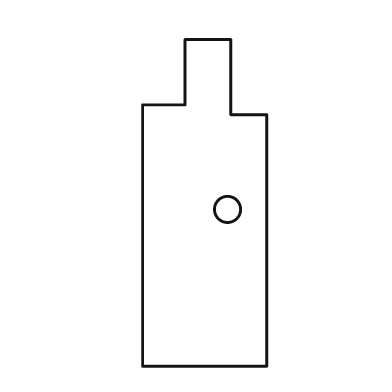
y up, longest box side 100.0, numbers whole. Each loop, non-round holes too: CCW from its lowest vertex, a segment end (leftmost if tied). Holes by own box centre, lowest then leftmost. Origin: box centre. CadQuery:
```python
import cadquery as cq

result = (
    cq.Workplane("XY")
    .moveTo(-19.0, -50.0)
    .lineTo(19.0, -50.0)
    .lineTo(19.0, 27.0)
    .lineTo(8.0, 27.0)
    .lineTo(8.0, 50.0)
    .lineTo(-6.0, 50.0)
    .lineTo(-6.0, 30.0)
    .lineTo(-19.0, 30.0)
    .close()
    .moveTo(7.0, -2.0)
    .circle(4.0)
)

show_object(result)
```